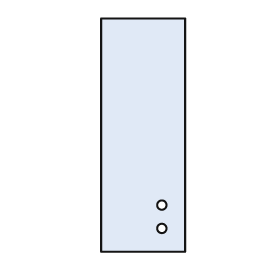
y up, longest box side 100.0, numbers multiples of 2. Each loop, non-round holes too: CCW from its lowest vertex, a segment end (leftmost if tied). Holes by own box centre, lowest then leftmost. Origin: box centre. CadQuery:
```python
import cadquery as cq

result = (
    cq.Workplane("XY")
    .moveTo(-18.0, -50.0)
    .lineTo(18.0, -50.0)
    .lineTo(18.0, 50.0)
    .lineTo(-18.0, 50.0)
    .close()
    .moveTo(8.0, -40.0)
    .circle(2.0)
    .moveTo(8.0, -30.0)
    .circle(2.0)
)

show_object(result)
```